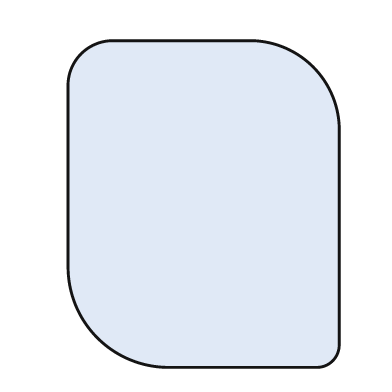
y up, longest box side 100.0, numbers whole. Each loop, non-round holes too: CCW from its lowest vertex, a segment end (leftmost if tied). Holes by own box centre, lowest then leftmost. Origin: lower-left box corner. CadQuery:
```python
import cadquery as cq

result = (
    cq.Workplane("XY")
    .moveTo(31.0, 0.0)
    .lineTo(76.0, 0.0)
    .threePointArc((81.0, 2.0), (83.0, 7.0))
    .lineTo(83.0, 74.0)
    .threePointArc((75.0, 92.0), (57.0, 100.0))
    .lineTo(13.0, 100.0)
    .threePointArc((4.0, 96.0), (0.0, 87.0))
    .lineTo(0.0, 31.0)
    .threePointArc((9.0, 9.0), (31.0, 0.0))
    .close()
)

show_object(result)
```